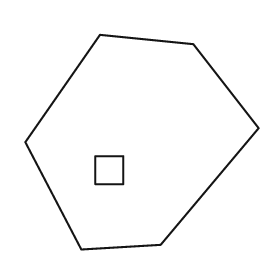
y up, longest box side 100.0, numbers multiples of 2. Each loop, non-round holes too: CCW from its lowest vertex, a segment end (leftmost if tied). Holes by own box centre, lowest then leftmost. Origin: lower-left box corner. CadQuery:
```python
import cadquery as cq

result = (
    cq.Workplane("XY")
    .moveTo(24.0, 0.0)
    .lineTo(58.0, 2.0)
    .lineTo(100.0, 52.0)
    .lineTo(72.0, 88.0)
    .lineTo(32.0, 92.0)
    .lineTo(0.0, 46.0)
    .close()
    .moveTo(30.0, 28.0)
    .lineTo(42.0, 28.0)
    .lineTo(42.0, 40.0)
    .lineTo(30.0, 40.0)
    .close()
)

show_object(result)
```